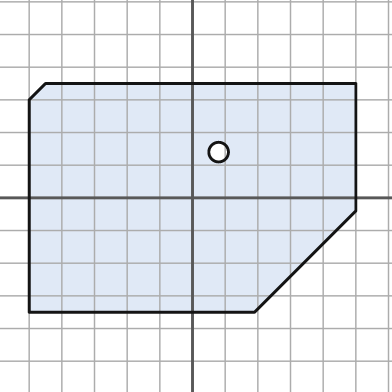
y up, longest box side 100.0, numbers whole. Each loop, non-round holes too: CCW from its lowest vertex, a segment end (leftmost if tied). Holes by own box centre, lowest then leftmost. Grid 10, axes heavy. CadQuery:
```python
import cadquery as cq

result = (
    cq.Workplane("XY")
    .moveTo(-50.0, -35.0)
    .lineTo(19.0, -35.0)
    .lineTo(50.0, -4.0)
    .lineTo(50.0, 35.0)
    .lineTo(-45.0, 35.0)
    .lineTo(-50.0, 30.0)
    .close()
    .moveTo(8.0, 14.0)
    .circle(3.0)
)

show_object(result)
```